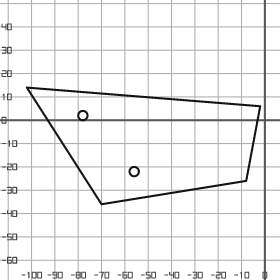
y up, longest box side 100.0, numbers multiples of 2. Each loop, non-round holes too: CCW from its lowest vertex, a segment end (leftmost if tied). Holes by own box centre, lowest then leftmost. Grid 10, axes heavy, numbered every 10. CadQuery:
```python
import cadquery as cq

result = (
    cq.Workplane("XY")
    .moveTo(-70.0, -36.0)
    .lineTo(-8.0, -26.0)
    .lineTo(-2.0, 6.0)
    .lineTo(-102.0, 14.0)
    .close()
    .moveTo(-56.0, -22.0)
    .circle(2.0)
    .moveTo(-78.0, 2.0)
    .circle(2.0)
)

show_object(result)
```